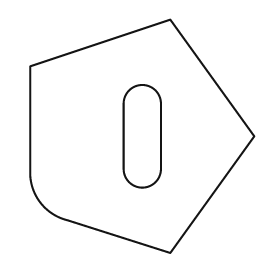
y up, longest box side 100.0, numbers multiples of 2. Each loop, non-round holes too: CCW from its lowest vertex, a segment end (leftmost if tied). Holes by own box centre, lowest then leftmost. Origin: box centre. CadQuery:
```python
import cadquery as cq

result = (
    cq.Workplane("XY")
    .moveTo(12.0, -50.0)
    .lineTo(48.0, 0.0)
    .lineTo(12.0, 50.0)
    .lineTo(-48.0, 30.0)
    .lineTo(-48.0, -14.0)
    .threePointArc((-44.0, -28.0), (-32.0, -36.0))
    .close()
    .moveTo(-8.0, -14.0)
    .threePointArc((0.0, -22.0), (8.0, -14.0))
    .lineTo(8.0, 14.0)
    .threePointArc((0.0, 22.0), (-8.0, 14.0))
    .close()
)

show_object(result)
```